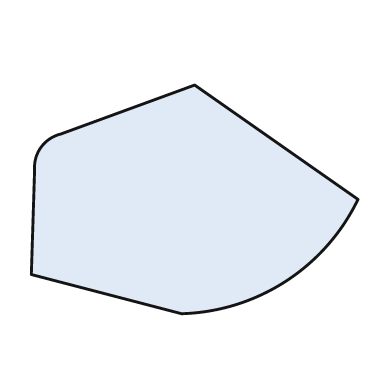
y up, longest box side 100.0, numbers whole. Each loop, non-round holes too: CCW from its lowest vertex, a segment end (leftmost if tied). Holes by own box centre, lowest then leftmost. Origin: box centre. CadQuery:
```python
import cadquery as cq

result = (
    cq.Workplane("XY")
    .moveTo(-4.0, -35.0)
    .threePointArc((28.0, -25.0), (50.0, 0.0))
    .lineTo(0.0, 35.0)
    .lineTo(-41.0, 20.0)
    .threePointArc((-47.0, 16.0), (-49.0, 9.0))
    .lineTo(-50.0, -23.0)
    .close()
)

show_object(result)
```